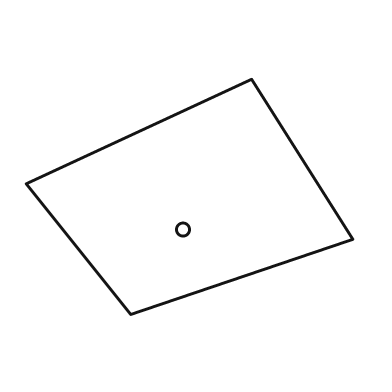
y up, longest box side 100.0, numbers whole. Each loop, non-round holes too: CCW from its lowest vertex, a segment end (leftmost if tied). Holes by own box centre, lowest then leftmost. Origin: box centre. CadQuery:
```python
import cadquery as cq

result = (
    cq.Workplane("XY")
    .moveTo(-18.0, -36.0)
    .lineTo(50.0, -13.0)
    .lineTo(19.0, 36.0)
    .lineTo(-50.0, 4.0)
    .close()
    .moveTo(-2.0, -10.0)
    .circle(2.0)
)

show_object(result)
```